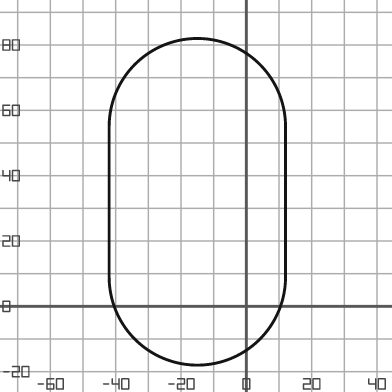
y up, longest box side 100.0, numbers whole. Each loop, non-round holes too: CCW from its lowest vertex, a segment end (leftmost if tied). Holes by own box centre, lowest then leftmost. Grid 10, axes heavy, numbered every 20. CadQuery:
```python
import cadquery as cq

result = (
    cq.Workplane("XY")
    .moveTo(-42.0, 9.0)
    .threePointArc((-15.0, -18.0), (12.0, 9.0))
    .lineTo(12.0, 55.0)
    .threePointArc((-15.0, 82.0), (-42.0, 55.0))
    .close()
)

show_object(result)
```